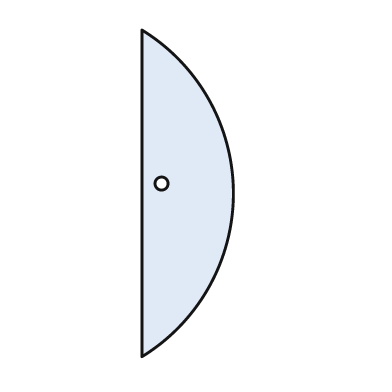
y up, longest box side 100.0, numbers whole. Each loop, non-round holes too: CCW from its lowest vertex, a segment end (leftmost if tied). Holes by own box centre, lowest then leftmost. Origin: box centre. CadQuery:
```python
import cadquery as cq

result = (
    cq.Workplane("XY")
    .moveTo(-14.0, -50.0)
    .threePointArc((14.0, 0.0), (-14.0, 50.0))
    .close()
    .moveTo(-8.0, 3.0)
    .circle(2.0)
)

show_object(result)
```